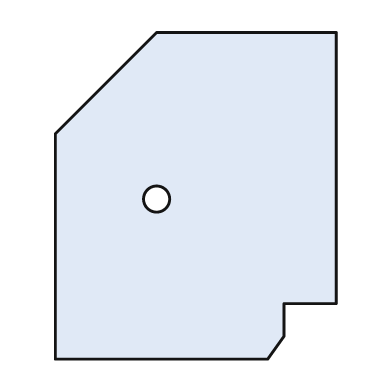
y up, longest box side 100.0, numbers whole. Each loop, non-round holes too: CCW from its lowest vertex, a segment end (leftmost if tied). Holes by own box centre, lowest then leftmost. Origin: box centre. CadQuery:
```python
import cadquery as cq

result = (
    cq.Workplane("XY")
    .moveTo(-43.0, -50.0)
    .lineTo(22.0, -50.0)
    .lineTo(27.0, -43.0)
    .lineTo(27.0, -33.0)
    .lineTo(43.0, -33.0)
    .lineTo(43.0, 50.0)
    .lineTo(-12.0, 50.0)
    .lineTo(-43.0, 19.0)
    .close()
    .moveTo(-12.0, -1.0)
    .circle(4.0)
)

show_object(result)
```